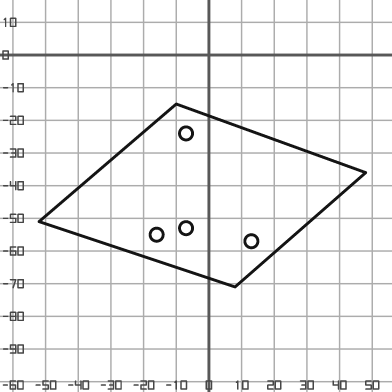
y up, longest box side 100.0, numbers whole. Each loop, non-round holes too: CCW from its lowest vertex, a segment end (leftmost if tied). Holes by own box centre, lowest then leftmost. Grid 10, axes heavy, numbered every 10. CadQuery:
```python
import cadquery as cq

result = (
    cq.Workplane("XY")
    .moveTo(8.0, -71.0)
    .lineTo(48.0, -36.0)
    .lineTo(-10.0, -15.0)
    .lineTo(-52.0, -51.0)
    .close()
    .moveTo(13.0, -57.0)
    .circle(2.0)
    .moveTo(-16.0, -55.0)
    .circle(2.0)
    .moveTo(-7.0, -53.0)
    .circle(2.0)
    .moveTo(-7.0, -24.0)
    .circle(2.0)
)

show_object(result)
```